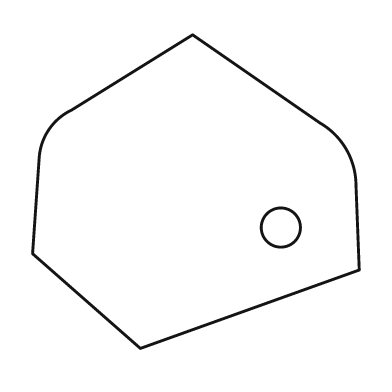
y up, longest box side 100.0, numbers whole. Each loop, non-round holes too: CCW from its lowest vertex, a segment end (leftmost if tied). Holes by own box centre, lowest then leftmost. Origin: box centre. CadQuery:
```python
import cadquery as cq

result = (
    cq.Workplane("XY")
    .moveTo(-17.0, -48.0)
    .lineTo(50.0, -24.0)
    .lineTo(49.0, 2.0)
    .threePointArc((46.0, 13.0), (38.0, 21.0))
    .lineTo(-1.0, 48.0)
    .lineTo(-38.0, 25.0)
    .threePointArc((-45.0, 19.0), (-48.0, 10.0))
    .lineTo(-50.0, -19.0)
    .close()
    .moveTo(26.0, -11.0)
    .circle(6.0)
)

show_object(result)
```